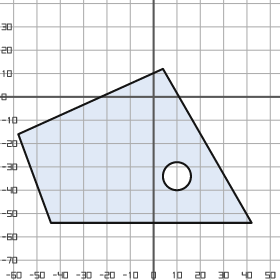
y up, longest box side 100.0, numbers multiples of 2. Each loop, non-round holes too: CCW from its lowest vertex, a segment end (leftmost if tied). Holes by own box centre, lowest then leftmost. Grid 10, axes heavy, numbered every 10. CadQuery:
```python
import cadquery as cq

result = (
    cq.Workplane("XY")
    .moveTo(-44.0, -54.0)
    .lineTo(42.0, -54.0)
    .lineTo(4.0, 12.0)
    .lineTo(-58.0, -16.0)
    .close()
    .moveTo(10.0, -34.0)
    .circle(6.0)
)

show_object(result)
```